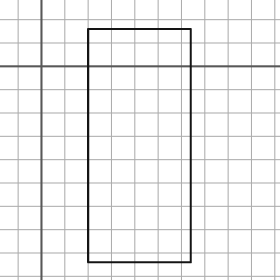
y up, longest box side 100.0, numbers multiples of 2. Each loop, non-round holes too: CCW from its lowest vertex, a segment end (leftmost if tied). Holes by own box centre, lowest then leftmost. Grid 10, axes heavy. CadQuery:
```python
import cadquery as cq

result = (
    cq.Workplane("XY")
    .moveTo(20.0, -84.0)
    .lineTo(64.0, -84.0)
    .lineTo(64.0, 16.0)
    .lineTo(20.0, 16.0)
    .close()
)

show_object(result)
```